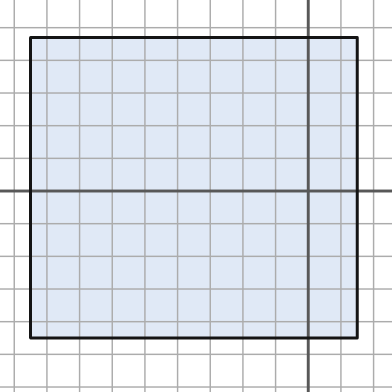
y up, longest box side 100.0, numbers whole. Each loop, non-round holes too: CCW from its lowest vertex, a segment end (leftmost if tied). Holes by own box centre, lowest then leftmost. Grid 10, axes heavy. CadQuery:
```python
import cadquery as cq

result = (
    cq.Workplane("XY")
    .moveTo(-85.0, -45.0)
    .lineTo(15.0, -45.0)
    .lineTo(15.0, 47.0)
    .lineTo(-85.0, 47.0)
    .close()
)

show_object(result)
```